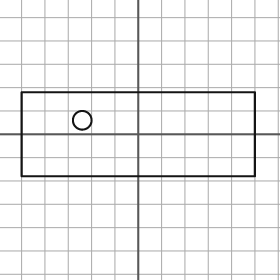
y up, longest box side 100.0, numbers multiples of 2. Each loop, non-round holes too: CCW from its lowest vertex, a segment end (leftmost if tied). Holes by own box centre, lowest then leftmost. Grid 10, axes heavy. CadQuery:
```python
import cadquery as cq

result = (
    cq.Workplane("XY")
    .moveTo(-50.0, -18.0)
    .lineTo(50.0, -18.0)
    .lineTo(50.0, 18.0)
    .lineTo(-50.0, 18.0)
    .close()
    .moveTo(-24.0, 6.0)
    .circle(4.0)
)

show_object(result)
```